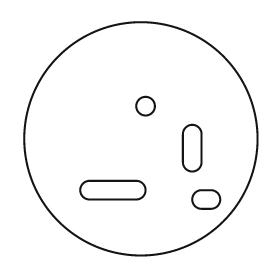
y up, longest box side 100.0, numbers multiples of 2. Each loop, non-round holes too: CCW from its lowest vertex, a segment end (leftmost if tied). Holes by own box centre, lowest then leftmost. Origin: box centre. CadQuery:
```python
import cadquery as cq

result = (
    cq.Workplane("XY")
    .moveTo(0.0, 0.0)
    .circle(50.0)
    .moveTo(26.0, -30.0)
    .lineTo(30.0, -30.0)
    .threePointArc((34.0, -26.0), (30.0, -22.0))
    .lineTo(26.0, -22.0)
    .threePointArc((22.0, -26.0), (26.0, -30.0))
    .close()
    .moveTo(-22.0, -26.0)
    .lineTo(-2.0, -26.0)
    .threePointArc((2.0, -22.0), (-2.0, -18.0))
    .lineTo(-22.0, -18.0)
    .threePointArc((-26.0, -22.0), (-22.0, -26.0))
    .close()
    .moveTo(18.0, -10.0)
    .threePointArc((22.0, -14.0), (26.0, -10.0))
    .lineTo(26.0, 2.0)
    .threePointArc((22.0, 6.0), (18.0, 2.0))
    .close()
    .moveTo(2.0, 14.0)
    .circle(4.0)
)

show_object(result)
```